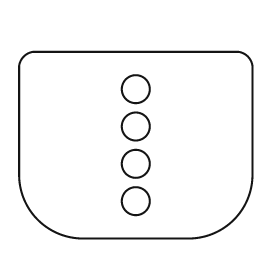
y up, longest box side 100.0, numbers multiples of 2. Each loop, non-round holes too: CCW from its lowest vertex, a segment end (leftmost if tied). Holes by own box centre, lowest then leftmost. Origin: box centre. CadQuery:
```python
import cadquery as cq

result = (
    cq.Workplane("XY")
    .moveTo(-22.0, -40.0)
    .lineTo(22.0, -40.0)
    .threePointArc((42.0, -32.0), (50.0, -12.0))
    .lineTo(50.0, 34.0)
    .threePointArc((48.0, 38.0), (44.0, 40.0))
    .lineTo(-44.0, 40.0)
    .threePointArc((-48.0, 38.0), (-50.0, 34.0))
    .lineTo(-50.0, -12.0)
    .threePointArc((-42.0, -32.0), (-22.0, -40.0))
    .close()
    .moveTo(0.0, -24.0)
    .circle(6.0)
    .moveTo(0.0, -8.0)
    .circle(6.0)
    .moveTo(0.0, 8.0)
    .circle(6.0)
    .moveTo(0.0, 24.0)
    .circle(6.0)
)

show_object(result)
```